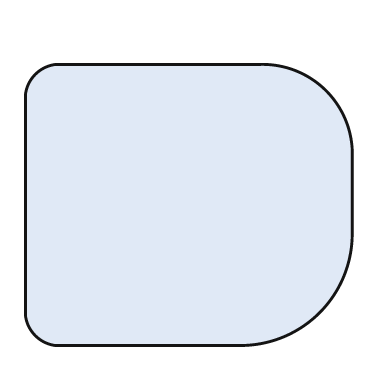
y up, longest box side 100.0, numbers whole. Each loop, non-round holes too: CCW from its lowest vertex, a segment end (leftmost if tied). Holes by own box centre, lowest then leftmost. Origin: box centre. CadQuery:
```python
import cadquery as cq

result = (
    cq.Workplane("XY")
    .moveTo(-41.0, -43.0)
    .lineTo(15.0, -43.0)
    .threePointArc((40.0, -33.0), (50.0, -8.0))
    .lineTo(50.0, 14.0)
    .threePointArc((42.0, 35.0), (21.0, 43.0))
    .lineTo(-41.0, 43.0)
    .threePointArc((-47.0, 40.0), (-50.0, 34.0))
    .lineTo(-50.0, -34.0)
    .threePointArc((-47.0, -40.0), (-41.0, -43.0))
    .close()
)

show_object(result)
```